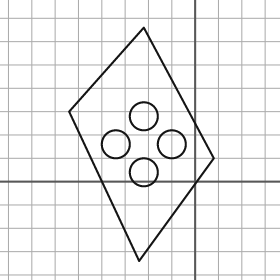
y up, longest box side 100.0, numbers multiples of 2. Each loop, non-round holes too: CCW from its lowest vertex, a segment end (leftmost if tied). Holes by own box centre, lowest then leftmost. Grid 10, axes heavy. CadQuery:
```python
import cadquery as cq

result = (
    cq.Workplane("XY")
    .moveTo(-24.0, -34.0)
    .lineTo(8.0, 10.0)
    .lineTo(-22.0, 66.0)
    .lineTo(-54.0, 30.0)
    .close()
    .moveTo(-22.0, 4.0)
    .circle(6.0)
    .moveTo(-34.0, 16.0)
    .circle(6.0)
    .moveTo(-10.0, 16.0)
    .circle(6.0)
    .moveTo(-22.0, 28.0)
    .circle(6.0)
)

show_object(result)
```